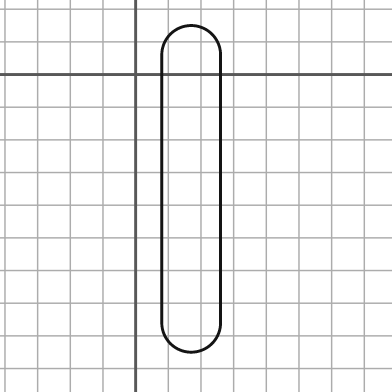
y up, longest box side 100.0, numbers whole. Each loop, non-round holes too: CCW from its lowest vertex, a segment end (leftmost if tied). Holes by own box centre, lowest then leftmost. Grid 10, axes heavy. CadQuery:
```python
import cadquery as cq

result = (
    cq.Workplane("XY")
    .moveTo(8.0, -76.0)
    .threePointArc((17.0, -85.0), (26.0, -76.0))
    .lineTo(26.0, 6.0)
    .threePointArc((17.0, 15.0), (8.0, 6.0))
    .close()
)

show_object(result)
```